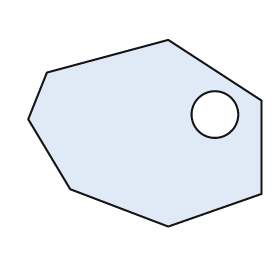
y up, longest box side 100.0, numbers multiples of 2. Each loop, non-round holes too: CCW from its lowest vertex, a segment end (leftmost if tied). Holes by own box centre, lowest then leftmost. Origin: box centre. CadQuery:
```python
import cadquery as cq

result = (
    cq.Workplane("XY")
    .moveTo(10.0, -40.0)
    .lineTo(50.0, -26.0)
    .lineTo(50.0, 14.0)
    .lineTo(10.0, 40.0)
    .lineTo(-42.0, 26.0)
    .lineTo(-50.0, 6.0)
    .lineTo(-32.0, -24.0)
    .close()
    .moveTo(30.0, 8.0)
    .circle(10.0)
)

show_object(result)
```